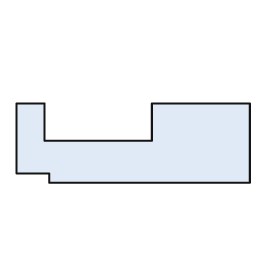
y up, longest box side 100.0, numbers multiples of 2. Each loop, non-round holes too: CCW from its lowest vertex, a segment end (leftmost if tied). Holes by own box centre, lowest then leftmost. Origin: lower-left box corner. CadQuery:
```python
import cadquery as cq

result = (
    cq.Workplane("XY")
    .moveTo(14.0, 0.0)
    .lineTo(100.0, 0.0)
    .lineTo(100.0, 34.0)
    .lineTo(58.0, 34.0)
    .lineTo(58.0, 18.0)
    .lineTo(12.0, 18.0)
    .lineTo(12.0, 34.0)
    .lineTo(0.0, 34.0)
    .lineTo(0.0, 4.0)
    .lineTo(14.0, 4.0)
    .close()
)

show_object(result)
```